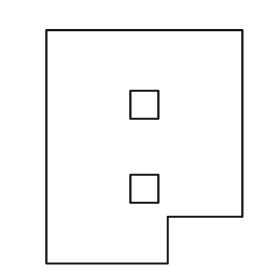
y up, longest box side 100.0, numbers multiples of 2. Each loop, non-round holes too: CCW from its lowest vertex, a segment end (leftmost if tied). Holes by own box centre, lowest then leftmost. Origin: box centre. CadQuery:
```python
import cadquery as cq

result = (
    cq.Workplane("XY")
    .moveTo(-42.0, -50.0)
    .lineTo(10.0, -50.0)
    .lineTo(10.0, -30.0)
    .lineTo(42.0, -30.0)
    .lineTo(42.0, 50.0)
    .lineTo(-42.0, 50.0)
    .close()
    .moveTo(-6.0, -24.0)
    .lineTo(6.0, -24.0)
    .lineTo(6.0, -12.0)
    .lineTo(-6.0, -12.0)
    .close()
    .moveTo(-6.0, 12.0)
    .lineTo(6.0, 12.0)
    .lineTo(6.0, 24.0)
    .lineTo(-6.0, 24.0)
    .close()
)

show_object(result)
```